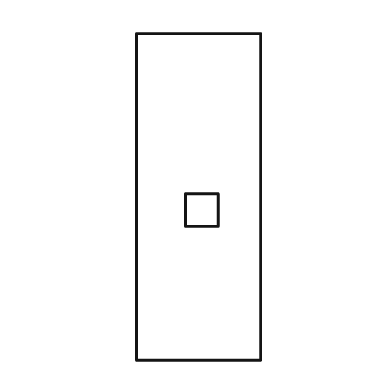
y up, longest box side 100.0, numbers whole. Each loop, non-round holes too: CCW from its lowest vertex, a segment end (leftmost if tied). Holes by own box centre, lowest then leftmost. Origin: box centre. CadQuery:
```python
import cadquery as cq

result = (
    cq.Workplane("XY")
    .moveTo(-19.0, -50.0)
    .lineTo(19.0, -50.0)
    .lineTo(19.0, 50.0)
    .lineTo(-19.0, 50.0)
    .close()
    .moveTo(-4.0, -9.0)
    .lineTo(6.0, -9.0)
    .lineTo(6.0, 1.0)
    .lineTo(-4.0, 1.0)
    .close()
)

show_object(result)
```